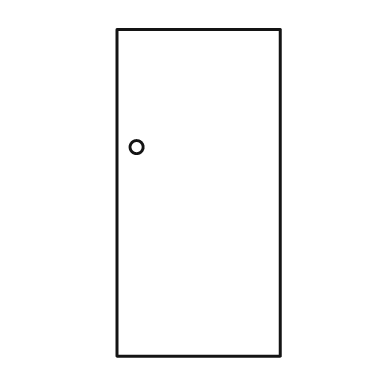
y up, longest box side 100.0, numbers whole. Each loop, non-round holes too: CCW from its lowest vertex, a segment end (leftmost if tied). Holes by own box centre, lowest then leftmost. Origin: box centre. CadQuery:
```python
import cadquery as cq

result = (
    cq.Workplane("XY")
    .moveTo(-25.0, -50.0)
    .lineTo(25.0, -50.0)
    .lineTo(25.0, 50.0)
    .lineTo(-25.0, 50.0)
    .close()
    .moveTo(-19.0, 14.0)
    .circle(2.0)
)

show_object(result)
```